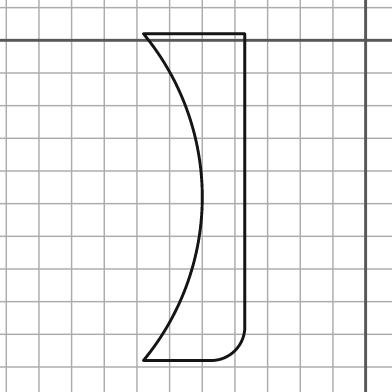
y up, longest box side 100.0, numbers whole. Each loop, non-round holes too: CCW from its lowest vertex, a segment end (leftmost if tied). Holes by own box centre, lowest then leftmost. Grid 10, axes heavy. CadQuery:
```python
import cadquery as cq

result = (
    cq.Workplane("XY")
    .moveTo(-68.0, -98.0)
    .lineTo(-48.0, -98.0)
    .threePointArc((-40.0, -95.0), (-37.0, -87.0))
    .lineTo(-37.0, 2.0)
    .lineTo(-68.0, 2.0)
    .threePointArc((-50.0, -48.0), (-68.0, -98.0))
    .close()
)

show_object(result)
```